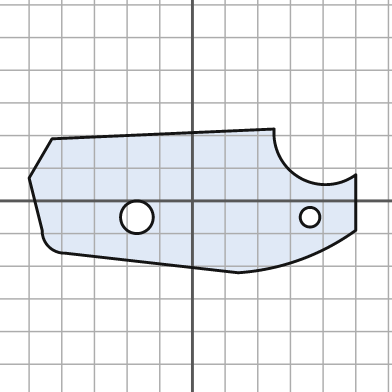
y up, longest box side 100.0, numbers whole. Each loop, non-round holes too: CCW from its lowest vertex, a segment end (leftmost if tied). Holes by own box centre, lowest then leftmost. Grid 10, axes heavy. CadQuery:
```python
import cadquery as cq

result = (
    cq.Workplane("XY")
    .moveTo(14.0, -22.0)
    .threePointArc((33.0, -18.0), (50.0, -9.0))
    .lineTo(50.0, 8.0)
    .threePointArc((33.0, 7.0), (25.0, 22.0))
    .lineTo(-43.0, 19.0)
    .lineTo(-50.0, 7.0)
    .lineTo(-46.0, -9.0)
    .threePointArc((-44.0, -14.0), (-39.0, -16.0))
    .close()
    .moveTo(-17.0, -5.0)
    .circle(5.0)
    .moveTo(36.0, -5.0)
    .circle(3.0)
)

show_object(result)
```